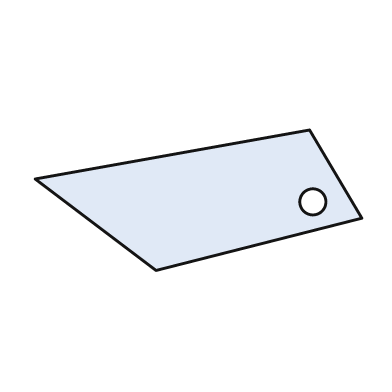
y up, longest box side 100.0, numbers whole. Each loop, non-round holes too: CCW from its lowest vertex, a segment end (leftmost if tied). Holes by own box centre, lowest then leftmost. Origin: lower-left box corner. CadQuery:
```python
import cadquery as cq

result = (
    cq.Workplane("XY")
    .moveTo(37.0, 0.0)
    .lineTo(100.0, 16.0)
    .lineTo(84.0, 43.0)
    .lineTo(0.0, 28.0)
    .close()
    .moveTo(85.0, 21.0)
    .circle(4.0)
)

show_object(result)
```